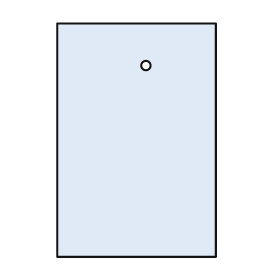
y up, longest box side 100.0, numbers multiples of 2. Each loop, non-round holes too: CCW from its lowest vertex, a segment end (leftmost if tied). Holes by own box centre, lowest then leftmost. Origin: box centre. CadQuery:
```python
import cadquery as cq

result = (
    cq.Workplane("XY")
    .moveTo(-34.0, -50.0)
    .lineTo(34.0, -50.0)
    .lineTo(34.0, 50.0)
    .lineTo(-34.0, 50.0)
    .close()
    .moveTo(4.0, 32.0)
    .circle(2.0)
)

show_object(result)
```